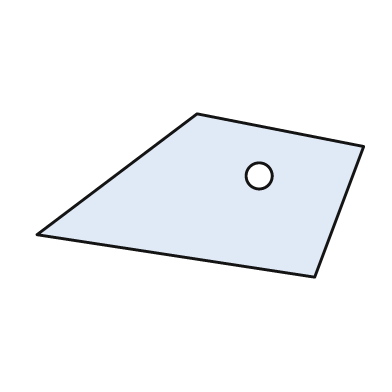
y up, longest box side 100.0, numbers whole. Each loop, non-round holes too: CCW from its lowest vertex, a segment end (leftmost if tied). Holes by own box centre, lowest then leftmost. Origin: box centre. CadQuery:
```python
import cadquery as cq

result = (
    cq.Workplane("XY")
    .moveTo(35.0, -25.0)
    .lineTo(50.0, 15.0)
    .lineTo(-1.0, 25.0)
    .lineTo(-50.0, -12.0)
    .close()
    .moveTo(18.0, 6.0)
    .circle(4.0)
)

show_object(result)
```